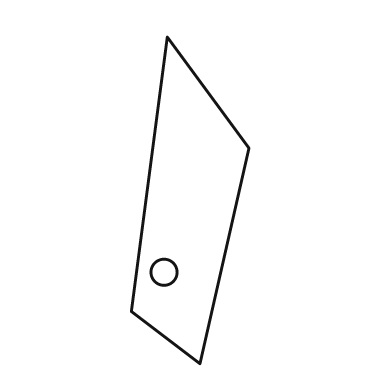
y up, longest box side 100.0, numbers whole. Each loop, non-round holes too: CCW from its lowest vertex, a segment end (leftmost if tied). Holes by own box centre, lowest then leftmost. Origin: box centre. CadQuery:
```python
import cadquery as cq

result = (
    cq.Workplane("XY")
    .moveTo(3.0, -50.0)
    .lineTo(18.0, 16.0)
    .lineTo(-7.0, 50.0)
    .lineTo(-18.0, -34.0)
    .close()
    .moveTo(-8.0, -22.0)
    .circle(4.0)
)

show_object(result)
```